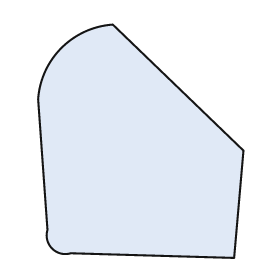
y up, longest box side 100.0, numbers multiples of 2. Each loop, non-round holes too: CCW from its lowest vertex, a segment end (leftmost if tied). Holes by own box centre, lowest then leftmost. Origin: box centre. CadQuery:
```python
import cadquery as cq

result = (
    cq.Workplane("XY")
    .moveTo(40.0, -50.0)
    .lineTo(44.0, -4.0)
    .lineTo(-12.0, 50.0)
    .threePointArc((-34.0, 40.0), (-44.0, 18.0))
    .lineTo(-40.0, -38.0)
    .threePointArc((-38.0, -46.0), (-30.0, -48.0))
    .close()
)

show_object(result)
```